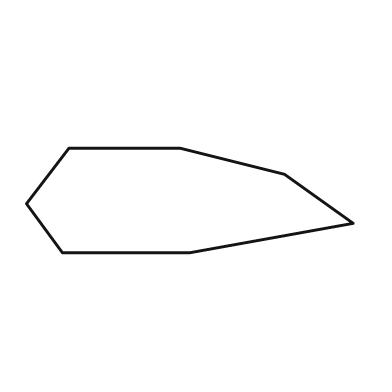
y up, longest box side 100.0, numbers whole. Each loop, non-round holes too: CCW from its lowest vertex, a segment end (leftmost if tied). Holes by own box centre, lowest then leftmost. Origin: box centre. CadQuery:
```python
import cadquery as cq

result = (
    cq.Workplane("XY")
    .moveTo(-39.0, -16.0)
    .lineTo(0.0, -16.0)
    .lineTo(50.0, -7.0)
    .lineTo(29.0, 8.0)
    .lineTo(-3.0, 16.0)
    .lineTo(-37.0, 16.0)
    .lineTo(-50.0, -1.0)
    .close()
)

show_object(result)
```